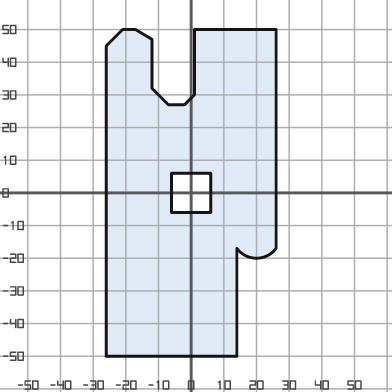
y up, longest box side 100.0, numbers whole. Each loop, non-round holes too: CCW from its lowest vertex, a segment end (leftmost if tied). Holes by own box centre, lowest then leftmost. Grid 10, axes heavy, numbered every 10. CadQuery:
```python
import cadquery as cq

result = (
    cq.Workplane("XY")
    .moveTo(-26.0, -50.0)
    .lineTo(14.0, -50.0)
    .lineTo(14.0, -17.0)
    .threePointArc((20.0, -20.0), (26.0, -17.0))
    .lineTo(26.0, 50.0)
    .lineTo(1.0, 50.0)
    .lineTo(1.0, 30.0)
    .lineTo(-2.0, 27.0)
    .lineTo(-7.0, 27.0)
    .lineTo(-12.0, 32.0)
    .lineTo(-12.0, 47.0)
    .lineTo(-17.0, 50.0)
    .lineTo(-21.0, 50.0)
    .lineTo(-26.0, 45.0)
    .close()
    .moveTo(-6.0, -6.0)
    .lineTo(6.0, -6.0)
    .lineTo(6.0, 6.0)
    .lineTo(-6.0, 6.0)
    .close()
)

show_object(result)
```